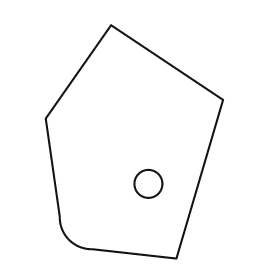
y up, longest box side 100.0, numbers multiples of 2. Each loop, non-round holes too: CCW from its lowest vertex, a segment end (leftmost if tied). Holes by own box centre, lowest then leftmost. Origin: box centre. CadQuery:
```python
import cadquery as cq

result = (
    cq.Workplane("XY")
    .moveTo(18.0, -50.0)
    .lineTo(38.0, 18.0)
    .lineTo(-10.0, 50.0)
    .lineTo(-38.0, 10.0)
    .lineTo(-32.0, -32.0)
    .threePointArc((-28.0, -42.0), (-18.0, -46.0))
    .close()
    .moveTo(6.0, -18.0)
    .circle(6.0)
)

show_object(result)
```